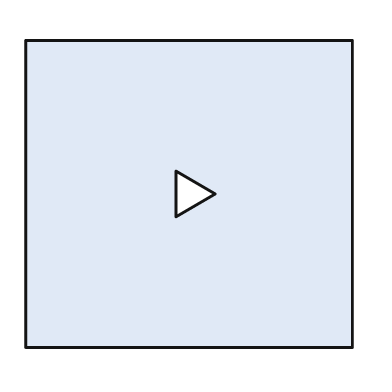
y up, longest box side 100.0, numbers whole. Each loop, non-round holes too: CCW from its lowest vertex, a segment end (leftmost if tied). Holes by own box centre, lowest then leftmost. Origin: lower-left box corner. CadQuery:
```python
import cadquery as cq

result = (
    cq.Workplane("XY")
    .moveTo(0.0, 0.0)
    .lineTo(100.0, 0.0)
    .lineTo(100.0, 94.0)
    .lineTo(0.0, 94.0)
    .close()
    .moveTo(46.0, 40.0)
    .lineTo(58.0, 47.0)
    .lineTo(46.0, 54.0)
    .close()
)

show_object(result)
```